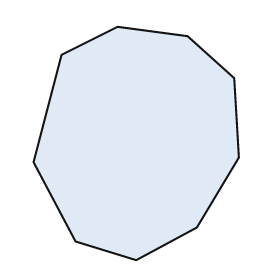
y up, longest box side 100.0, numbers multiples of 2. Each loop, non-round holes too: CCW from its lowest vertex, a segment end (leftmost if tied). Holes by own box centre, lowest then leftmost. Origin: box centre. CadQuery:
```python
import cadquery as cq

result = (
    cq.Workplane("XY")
    .moveTo(0.0, -50.0)
    .lineTo(26.0, -36.0)
    .lineTo(44.0, -6.0)
    .lineTo(42.0, 28.0)
    .lineTo(22.0, 46.0)
    .lineTo(-8.0, 50.0)
    .lineTo(-32.0, 38.0)
    .lineTo(-44.0, -8.0)
    .lineTo(-26.0, -42.0)
    .close()
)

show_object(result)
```